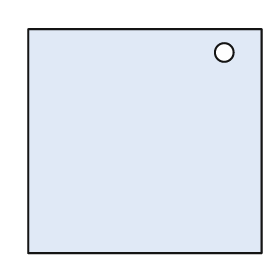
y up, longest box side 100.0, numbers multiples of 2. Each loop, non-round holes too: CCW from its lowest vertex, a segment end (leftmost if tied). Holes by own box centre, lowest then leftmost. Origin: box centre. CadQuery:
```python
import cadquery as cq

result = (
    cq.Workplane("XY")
    .moveTo(-50.0, -48.0)
    .lineTo(50.0, -48.0)
    .lineTo(50.0, 48.0)
    .lineTo(-50.0, 48.0)
    .close()
    .moveTo(34.0, 38.0)
    .circle(4.0)
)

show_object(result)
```